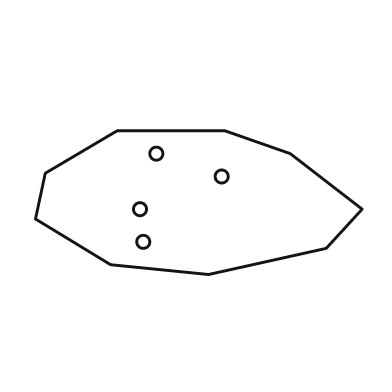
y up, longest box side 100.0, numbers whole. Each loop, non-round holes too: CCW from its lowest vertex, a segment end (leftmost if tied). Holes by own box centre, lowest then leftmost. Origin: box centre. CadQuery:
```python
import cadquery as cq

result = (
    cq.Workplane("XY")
    .moveTo(3.0, -22.0)
    .lineTo(39.0, -14.0)
    .lineTo(50.0, -2.0)
    .lineTo(28.0, 15.0)
    .lineTo(8.0, 22.0)
    .lineTo(-25.0, 22.0)
    .lineTo(-47.0, 9.0)
    .lineTo(-50.0, -5.0)
    .lineTo(-27.0, -19.0)
    .close()
    .moveTo(-17.0, -12.0)
    .circle(2.0)
    .moveTo(-18.0, -2.0)
    .circle(2.0)
    .moveTo(7.0, 8.0)
    .circle(2.0)
    .moveTo(-13.0, 15.0)
    .circle(2.0)
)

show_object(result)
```